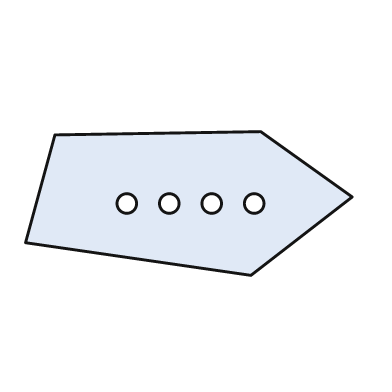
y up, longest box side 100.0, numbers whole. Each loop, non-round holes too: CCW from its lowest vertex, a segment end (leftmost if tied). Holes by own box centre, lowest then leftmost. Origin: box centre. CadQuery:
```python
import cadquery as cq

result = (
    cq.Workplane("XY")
    .moveTo(19.0, -22.0)
    .lineTo(50.0, 2.0)
    .lineTo(22.0, 22.0)
    .lineTo(-41.0, 21.0)
    .lineTo(-50.0, -12.0)
    .close()
    .moveTo(-19.0, 0.0)
    .circle(3.0)
    .moveTo(-6.0, 0.0)
    .circle(3.0)
    .moveTo(7.0, 0.0)
    .circle(3.0)
    .moveTo(20.0, 0.0)
    .circle(3.0)
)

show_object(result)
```